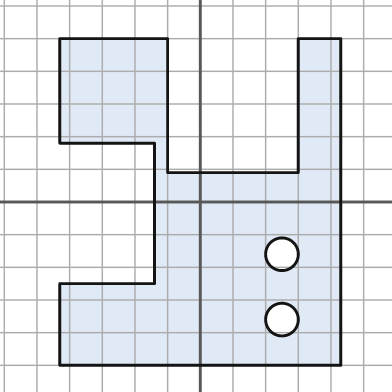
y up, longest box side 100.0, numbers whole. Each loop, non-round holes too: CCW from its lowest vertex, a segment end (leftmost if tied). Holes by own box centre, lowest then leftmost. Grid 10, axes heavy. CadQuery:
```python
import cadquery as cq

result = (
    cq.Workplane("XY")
    .moveTo(-43.0, -50.0)
    .lineTo(43.0, -50.0)
    .lineTo(43.0, 50.0)
    .lineTo(30.0, 50.0)
    .lineTo(30.0, 9.0)
    .lineTo(-10.0, 9.0)
    .lineTo(-10.0, 50.0)
    .lineTo(-43.0, 50.0)
    .lineTo(-43.0, 18.0)
    .lineTo(-14.0, 18.0)
    .lineTo(-14.0, -25.0)
    .lineTo(-43.0, -25.0)
    .close()
    .moveTo(25.0, -36.0)
    .circle(5.0)
    .moveTo(25.0, -16.0)
    .circle(5.0)
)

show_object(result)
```